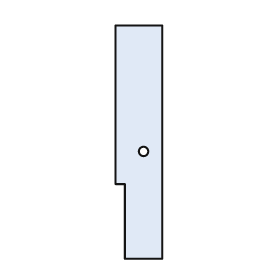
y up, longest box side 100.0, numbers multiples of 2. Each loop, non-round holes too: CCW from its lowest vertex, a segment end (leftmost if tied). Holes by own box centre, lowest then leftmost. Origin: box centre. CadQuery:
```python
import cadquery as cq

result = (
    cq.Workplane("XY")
    .moveTo(-6.0, -50.0)
    .lineTo(10.0, -50.0)
    .lineTo(10.0, 50.0)
    .lineTo(-10.0, 50.0)
    .lineTo(-10.0, -18.0)
    .lineTo(-6.0, -18.0)
    .close()
    .moveTo(2.0, -4.0)
    .circle(2.0)
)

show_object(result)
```